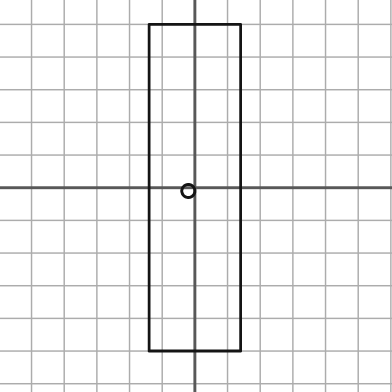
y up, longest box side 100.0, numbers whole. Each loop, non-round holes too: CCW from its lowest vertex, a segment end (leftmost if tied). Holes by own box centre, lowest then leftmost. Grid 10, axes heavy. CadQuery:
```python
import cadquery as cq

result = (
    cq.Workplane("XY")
    .moveTo(-14.0, -50.0)
    .lineTo(14.0, -50.0)
    .lineTo(14.0, 50.0)
    .lineTo(-14.0, 50.0)
    .close()
    .moveTo(-2.0, -1.0)
    .circle(2.0)
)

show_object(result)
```